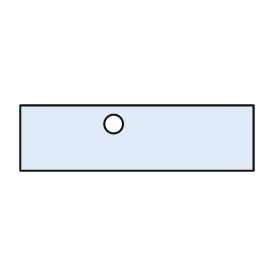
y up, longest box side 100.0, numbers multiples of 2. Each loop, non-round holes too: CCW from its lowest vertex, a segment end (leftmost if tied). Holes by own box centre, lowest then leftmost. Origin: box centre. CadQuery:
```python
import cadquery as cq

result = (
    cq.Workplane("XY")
    .moveTo(-50.0, -14.0)
    .lineTo(50.0, -14.0)
    .lineTo(50.0, 14.0)
    .lineTo(-50.0, 14.0)
    .close()
    .moveTo(-10.0, 6.0)
    .circle(4.0)
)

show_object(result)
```